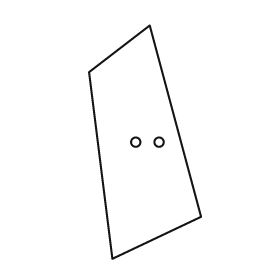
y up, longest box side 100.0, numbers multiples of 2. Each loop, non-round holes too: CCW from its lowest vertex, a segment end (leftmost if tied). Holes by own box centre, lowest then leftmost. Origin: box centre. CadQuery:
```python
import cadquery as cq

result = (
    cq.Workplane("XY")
    .moveTo(-14.0, -50.0)
    .lineTo(24.0, -32.0)
    .lineTo(2.0, 50.0)
    .lineTo(-24.0, 30.0)
    .close()
    .moveTo(-4.0, 0.0)
    .circle(2.0)
    .moveTo(6.0, 0.0)
    .circle(2.0)
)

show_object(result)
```